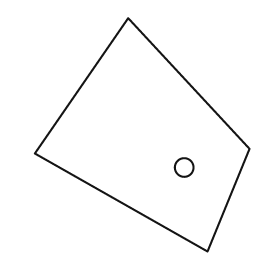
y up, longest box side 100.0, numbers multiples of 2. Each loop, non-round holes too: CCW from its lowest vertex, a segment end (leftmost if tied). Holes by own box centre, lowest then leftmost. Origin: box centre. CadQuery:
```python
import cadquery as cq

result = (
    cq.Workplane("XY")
    .moveTo(28.0, -50.0)
    .lineTo(46.0, -6.0)
    .lineTo(-6.0, 50.0)
    .lineTo(-46.0, -8.0)
    .close()
    .moveTo(18.0, -14.0)
    .circle(4.0)
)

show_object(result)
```